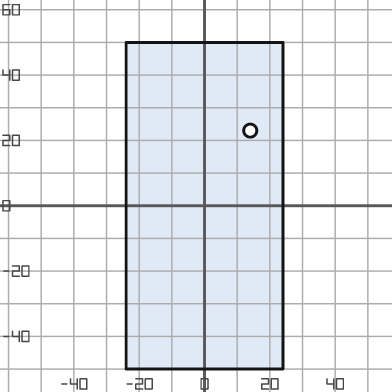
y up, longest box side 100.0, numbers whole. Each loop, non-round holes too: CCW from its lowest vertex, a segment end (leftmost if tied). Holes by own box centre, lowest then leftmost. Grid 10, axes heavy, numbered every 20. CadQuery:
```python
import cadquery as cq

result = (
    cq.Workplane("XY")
    .moveTo(-24.0, -50.0)
    .lineTo(24.0, -50.0)
    .lineTo(24.0, 50.0)
    .lineTo(-24.0, 50.0)
    .close()
    .moveTo(14.0, 23.0)
    .circle(2.0)
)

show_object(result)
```